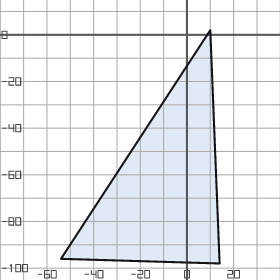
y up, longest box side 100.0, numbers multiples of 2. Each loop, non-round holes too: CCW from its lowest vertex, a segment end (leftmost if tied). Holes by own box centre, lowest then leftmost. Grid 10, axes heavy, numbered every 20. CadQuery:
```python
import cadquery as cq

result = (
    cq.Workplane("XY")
    .moveTo(14.0, -98.0)
    .lineTo(10.0, 2.0)
    .lineTo(-54.0, -96.0)
    .close()
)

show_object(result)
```